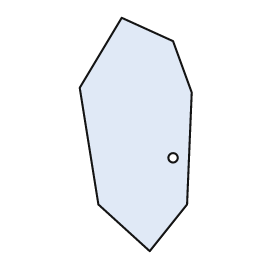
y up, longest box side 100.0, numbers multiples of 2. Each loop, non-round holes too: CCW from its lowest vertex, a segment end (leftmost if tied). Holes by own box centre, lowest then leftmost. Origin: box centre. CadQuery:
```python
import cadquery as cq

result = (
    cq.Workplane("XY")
    .moveTo(6.0, -50.0)
    .lineTo(22.0, -30.0)
    .lineTo(24.0, 18.0)
    .lineTo(16.0, 40.0)
    .lineTo(-6.0, 50.0)
    .lineTo(-24.0, 20.0)
    .lineTo(-16.0, -30.0)
    .close()
    .moveTo(16.0, -10.0)
    .circle(2.0)
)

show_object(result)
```